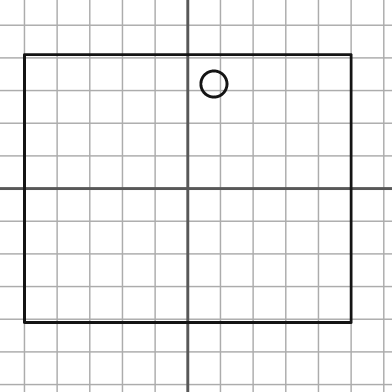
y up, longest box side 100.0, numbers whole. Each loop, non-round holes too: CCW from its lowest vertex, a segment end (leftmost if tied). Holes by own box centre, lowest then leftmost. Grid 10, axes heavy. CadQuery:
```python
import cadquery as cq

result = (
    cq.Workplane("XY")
    .moveTo(-50.0, -41.0)
    .lineTo(50.0, -41.0)
    .lineTo(50.0, 41.0)
    .lineTo(-50.0, 41.0)
    .close()
    .moveTo(8.0, 32.0)
    .circle(4.0)
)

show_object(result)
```